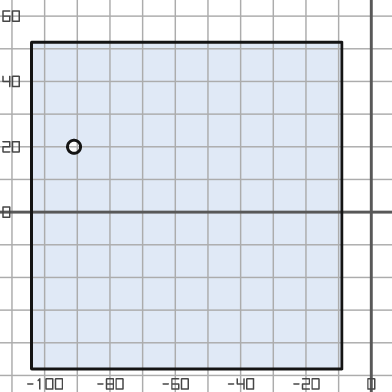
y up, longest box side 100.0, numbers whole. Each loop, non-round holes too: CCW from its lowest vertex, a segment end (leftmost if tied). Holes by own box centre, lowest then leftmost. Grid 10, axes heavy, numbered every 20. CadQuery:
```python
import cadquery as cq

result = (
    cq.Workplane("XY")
    .moveTo(-104.0, -48.0)
    .lineTo(-9.0, -48.0)
    .lineTo(-9.0, 52.0)
    .lineTo(-104.0, 52.0)
    .close()
    .moveTo(-91.0, 20.0)
    .circle(2.0)
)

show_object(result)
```